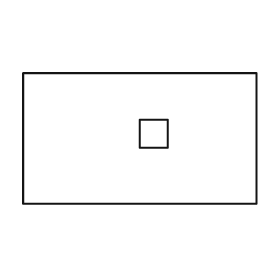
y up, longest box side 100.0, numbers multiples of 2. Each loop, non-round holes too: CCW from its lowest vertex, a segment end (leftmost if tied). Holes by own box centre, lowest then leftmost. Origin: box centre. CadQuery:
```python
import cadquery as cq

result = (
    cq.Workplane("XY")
    .moveTo(-50.0, -28.0)
    .lineTo(50.0, -28.0)
    .lineTo(50.0, 28.0)
    .lineTo(-50.0, 28.0)
    .close()
    .moveTo(0.0, -4.0)
    .lineTo(12.0, -4.0)
    .lineTo(12.0, 8.0)
    .lineTo(0.0, 8.0)
    .close()
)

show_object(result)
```